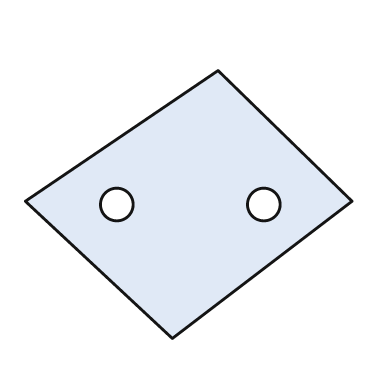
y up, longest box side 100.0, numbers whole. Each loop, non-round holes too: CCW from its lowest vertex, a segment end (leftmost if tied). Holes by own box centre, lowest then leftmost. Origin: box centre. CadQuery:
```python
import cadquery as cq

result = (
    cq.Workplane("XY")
    .moveTo(-5.0, -41.0)
    .lineTo(50.0, 1.0)
    .lineTo(9.0, 41.0)
    .lineTo(-50.0, 1.0)
    .close()
    .moveTo(-22.0, 0.0)
    .circle(5.0)
    .moveTo(23.0, 0.0)
    .circle(5.0)
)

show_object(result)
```